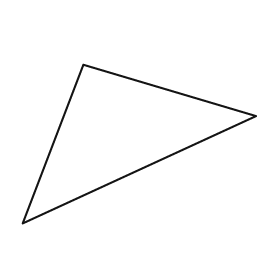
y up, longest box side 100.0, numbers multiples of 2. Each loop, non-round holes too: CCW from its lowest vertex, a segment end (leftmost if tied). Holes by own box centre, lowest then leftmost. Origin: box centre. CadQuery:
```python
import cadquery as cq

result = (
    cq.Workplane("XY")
    .moveTo(-50.0, -34.0)
    .lineTo(50.0, 12.0)
    .lineTo(-24.0, 34.0)
    .close()
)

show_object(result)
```